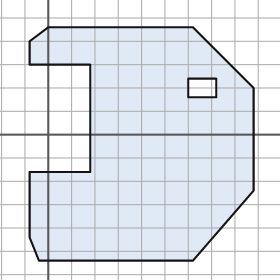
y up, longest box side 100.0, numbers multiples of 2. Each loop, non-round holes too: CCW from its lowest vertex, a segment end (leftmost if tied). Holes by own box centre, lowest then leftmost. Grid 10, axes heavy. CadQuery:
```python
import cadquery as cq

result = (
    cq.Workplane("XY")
    .moveTo(-4.0, -54.0)
    .lineTo(62.0, -54.0)
    .lineTo(88.0, -24.0)
    .lineTo(88.0, 20.0)
    .lineTo(62.0, 46.0)
    .lineTo(0.0, 46.0)
    .lineTo(-8.0, 40.0)
    .lineTo(-8.0, 30.0)
    .lineTo(18.0, 30.0)
    .lineTo(18.0, -16.0)
    .lineTo(-8.0, -16.0)
    .lineTo(-8.0, -44.0)
    .close()
    .moveTo(60.0, 16.0)
    .lineTo(72.0, 16.0)
    .lineTo(72.0, 24.0)
    .lineTo(60.0, 24.0)
    .close()
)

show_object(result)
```